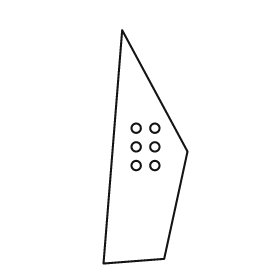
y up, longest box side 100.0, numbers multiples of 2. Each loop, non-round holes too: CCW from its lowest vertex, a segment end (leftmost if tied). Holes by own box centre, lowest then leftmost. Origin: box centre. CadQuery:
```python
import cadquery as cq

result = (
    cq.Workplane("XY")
    .moveTo(-18.0, -50.0)
    .lineTo(8.0, -48.0)
    .lineTo(18.0, -2.0)
    .lineTo(-10.0, 50.0)
    .close()
    .moveTo(-4.0, -8.0)
    .circle(2.0)
    .moveTo(4.0, -8.0)
    .circle(2.0)
    .moveTo(-4.0, 0.0)
    .circle(2.0)
    .moveTo(4.0, 0.0)
    .circle(2.0)
    .moveTo(-4.0, 8.0)
    .circle(2.0)
    .moveTo(4.0, 8.0)
    .circle(2.0)
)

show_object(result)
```